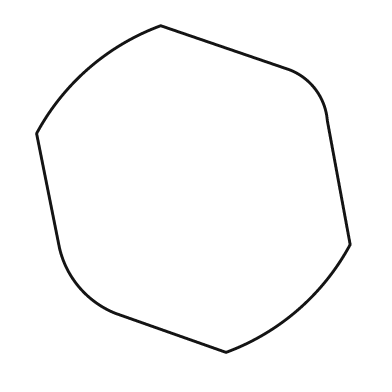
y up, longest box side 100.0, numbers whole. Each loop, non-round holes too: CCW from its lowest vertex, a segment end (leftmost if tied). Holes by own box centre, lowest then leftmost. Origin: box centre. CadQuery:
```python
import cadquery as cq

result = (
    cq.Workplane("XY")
    .moveTo(10.0, -50.0)
    .threePointArc((32.0, -37.0), (48.0, -17.0))
    .lineTo(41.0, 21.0)
    .threePointArc((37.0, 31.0), (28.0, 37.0))
    .lineTo(-10.0, 50.0)
    .threePointArc((-32.0, 37.0), (-48.0, 17.0))
    .lineTo(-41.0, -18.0)
    .threePointArc((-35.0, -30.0), (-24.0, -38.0))
    .close()
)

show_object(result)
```